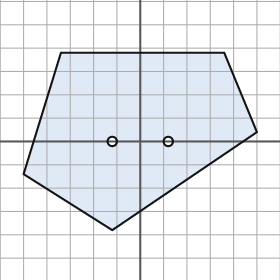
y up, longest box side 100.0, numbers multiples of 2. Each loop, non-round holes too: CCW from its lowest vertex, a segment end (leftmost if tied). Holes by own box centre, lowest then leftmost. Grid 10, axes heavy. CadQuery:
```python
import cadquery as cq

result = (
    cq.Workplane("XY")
    .moveTo(-12.0, -38.0)
    .lineTo(50.0, 4.0)
    .lineTo(36.0, 38.0)
    .lineTo(-34.0, 38.0)
    .lineTo(-50.0, -14.0)
    .close()
    .moveTo(-12.0, 0.0)
    .circle(2.0)
    .moveTo(12.0, 0.0)
    .circle(2.0)
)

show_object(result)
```